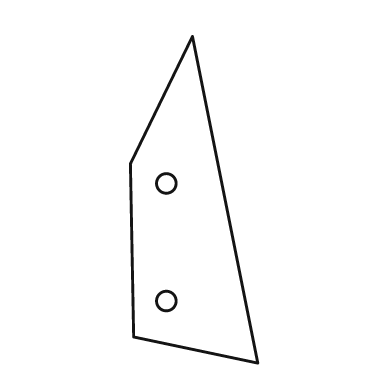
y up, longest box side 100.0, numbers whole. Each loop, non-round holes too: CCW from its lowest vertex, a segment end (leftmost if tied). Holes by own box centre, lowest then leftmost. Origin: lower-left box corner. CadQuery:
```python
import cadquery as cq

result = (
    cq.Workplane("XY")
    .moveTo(39.0, 0.0)
    .lineTo(19.0, 100.0)
    .lineTo(0.0, 61.0)
    .lineTo(1.0, 8.0)
    .close()
    .moveTo(11.0, 19.0)
    .circle(3.0)
    .moveTo(11.0, 55.0)
    .circle(3.0)
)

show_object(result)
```